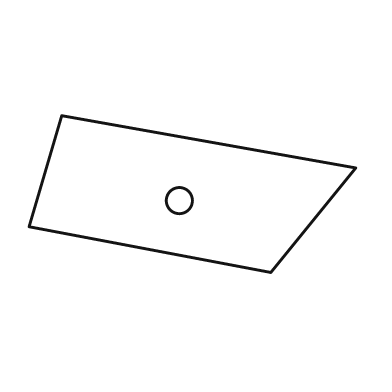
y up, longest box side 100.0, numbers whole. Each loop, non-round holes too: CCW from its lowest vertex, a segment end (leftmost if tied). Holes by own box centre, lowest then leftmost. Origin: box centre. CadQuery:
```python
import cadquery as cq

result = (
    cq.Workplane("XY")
    .moveTo(24.0, -24.0)
    .lineTo(50.0, 8.0)
    .lineTo(-40.0, 24.0)
    .lineTo(-50.0, -10.0)
    .close()
    .moveTo(-4.0, -2.0)
    .circle(4.0)
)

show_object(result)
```